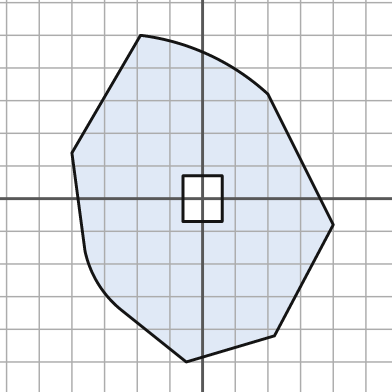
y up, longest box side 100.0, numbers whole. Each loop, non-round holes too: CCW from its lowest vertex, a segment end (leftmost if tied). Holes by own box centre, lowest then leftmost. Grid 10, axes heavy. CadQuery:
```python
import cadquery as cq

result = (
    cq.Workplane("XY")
    .moveTo(-5.0, -50.0)
    .lineTo(22.0, -42.0)
    .lineTo(40.0, -8.0)
    .lineTo(20.0, 32.0)
    .threePointArc((2.0, 44.0), (-19.0, 50.0))
    .lineTo(-40.0, 14.0)
    .lineTo(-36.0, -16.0)
    .threePointArc((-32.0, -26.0), (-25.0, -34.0))
    .close()
    .moveTo(-6.0, -7.0)
    .lineTo(6.0, -7.0)
    .lineTo(6.0, 7.0)
    .lineTo(-6.0, 7.0)
    .close()
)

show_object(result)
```